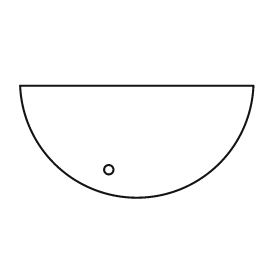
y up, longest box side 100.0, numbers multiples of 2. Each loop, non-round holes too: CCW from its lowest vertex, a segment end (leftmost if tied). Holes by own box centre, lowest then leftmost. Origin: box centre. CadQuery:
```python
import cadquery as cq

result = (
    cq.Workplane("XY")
    .moveTo(-50.0, 24.0)
    .threePointArc((0.0, -24.0), (50.0, 24.0))
    .close()
    .moveTo(-12.0, -12.0)
    .circle(2.0)
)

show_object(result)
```